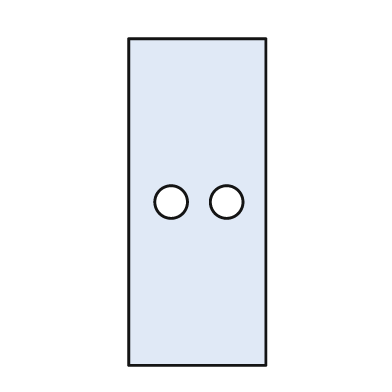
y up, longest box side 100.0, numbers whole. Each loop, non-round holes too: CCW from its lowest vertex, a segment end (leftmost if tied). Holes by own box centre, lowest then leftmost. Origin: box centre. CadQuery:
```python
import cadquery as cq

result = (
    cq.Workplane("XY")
    .moveTo(-21.0, -50.0)
    .lineTo(21.0, -50.0)
    .lineTo(21.0, 50.0)
    .lineTo(-21.0, 50.0)
    .close()
    .moveTo(-8.0, 0.0)
    .circle(5.0)
    .moveTo(9.0, 0.0)
    .circle(5.0)
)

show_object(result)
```